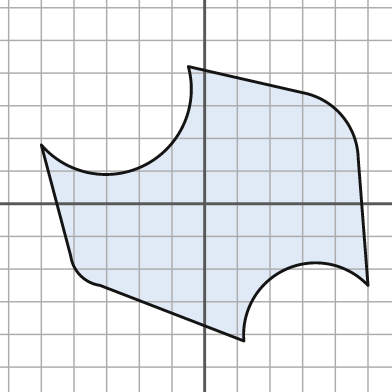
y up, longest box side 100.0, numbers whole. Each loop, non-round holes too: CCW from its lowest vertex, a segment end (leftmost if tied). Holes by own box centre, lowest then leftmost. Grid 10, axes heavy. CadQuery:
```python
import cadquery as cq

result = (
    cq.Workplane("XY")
    .moveTo(12.0, -42.0)
    .threePointArc((25.0, -20.0), (50.0, -25.0))
    .lineTo(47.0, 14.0)
    .threePointArc((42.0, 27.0), (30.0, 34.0))
    .lineTo(-5.0, 42.0)
    .threePointArc((-18.0, 12.0), (-50.0, 18.0))
    .lineTo(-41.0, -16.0)
    .threePointArc((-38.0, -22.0), (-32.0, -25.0))
    .close()
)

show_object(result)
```